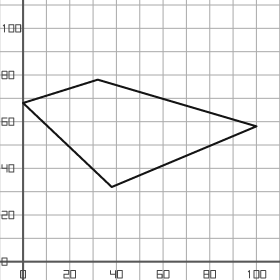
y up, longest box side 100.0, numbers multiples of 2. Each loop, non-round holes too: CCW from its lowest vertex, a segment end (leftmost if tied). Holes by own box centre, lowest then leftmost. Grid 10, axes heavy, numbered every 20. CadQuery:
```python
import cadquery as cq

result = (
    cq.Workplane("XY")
    .moveTo(38.0, 32.0)
    .lineTo(100.0, 58.0)
    .lineTo(32.0, 78.0)
    .lineTo(0.0, 68.0)
    .close()
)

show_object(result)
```